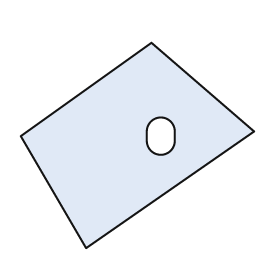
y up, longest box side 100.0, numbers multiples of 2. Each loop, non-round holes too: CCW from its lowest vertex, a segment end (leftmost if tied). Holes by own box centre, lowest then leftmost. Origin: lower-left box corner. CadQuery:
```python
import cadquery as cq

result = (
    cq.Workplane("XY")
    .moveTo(28.0, 0.0)
    .lineTo(100.0, 50.0)
    .lineTo(56.0, 88.0)
    .lineTo(0.0, 48.0)
    .close()
    .moveTo(54.0, 46.0)
    .threePointArc((60.0, 40.0), (66.0, 46.0))
    .lineTo(66.0, 50.0)
    .threePointArc((60.0, 56.0), (54.0, 50.0))
    .close()
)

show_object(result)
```